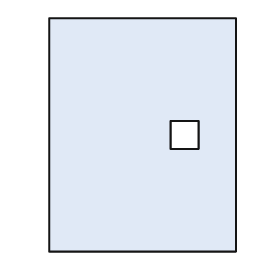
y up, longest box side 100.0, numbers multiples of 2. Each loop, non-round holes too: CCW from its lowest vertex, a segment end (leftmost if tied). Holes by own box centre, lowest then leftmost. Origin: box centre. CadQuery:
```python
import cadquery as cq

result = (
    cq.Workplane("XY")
    .moveTo(-40.0, -50.0)
    .lineTo(40.0, -50.0)
    .lineTo(40.0, 50.0)
    .lineTo(-40.0, 50.0)
    .close()
    .moveTo(12.0, -6.0)
    .lineTo(24.0, -6.0)
    .lineTo(24.0, 6.0)
    .lineTo(12.0, 6.0)
    .close()
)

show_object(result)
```